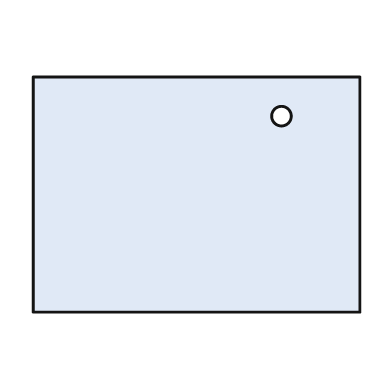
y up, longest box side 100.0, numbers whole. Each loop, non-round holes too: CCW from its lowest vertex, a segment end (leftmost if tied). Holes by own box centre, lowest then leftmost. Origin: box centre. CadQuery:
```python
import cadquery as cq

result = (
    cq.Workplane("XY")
    .moveTo(-50.0, -36.0)
    .lineTo(50.0, -36.0)
    .lineTo(50.0, 36.0)
    .lineTo(-50.0, 36.0)
    .close()
    .moveTo(26.0, 24.0)
    .circle(3.0)
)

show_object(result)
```